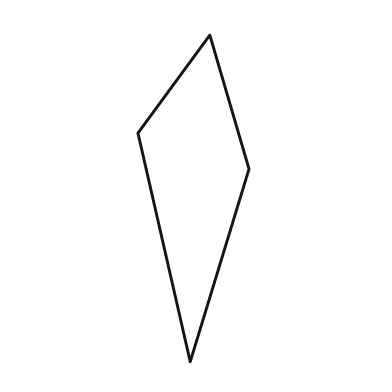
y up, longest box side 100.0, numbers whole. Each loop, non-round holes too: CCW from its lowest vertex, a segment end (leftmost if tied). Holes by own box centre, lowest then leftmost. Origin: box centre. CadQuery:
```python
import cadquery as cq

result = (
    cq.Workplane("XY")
    .moveTo(-1.0, -50.0)
    .lineTo(17.0, 9.0)
    .lineTo(5.0, 50.0)
    .lineTo(-17.0, 20.0)
    .close()
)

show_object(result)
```